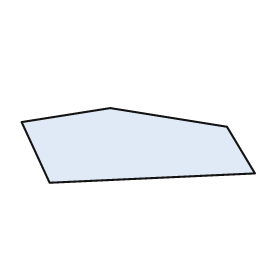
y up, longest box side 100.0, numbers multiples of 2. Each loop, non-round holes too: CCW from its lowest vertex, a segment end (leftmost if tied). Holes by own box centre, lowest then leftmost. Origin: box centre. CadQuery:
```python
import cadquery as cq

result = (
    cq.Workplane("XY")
    .moveTo(-38.0, -16.0)
    .lineTo(50.0, -12.0)
    .lineTo(38.0, 8.0)
    .lineTo(-12.0, 16.0)
    .lineTo(-50.0, 10.0)
    .close()
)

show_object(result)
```